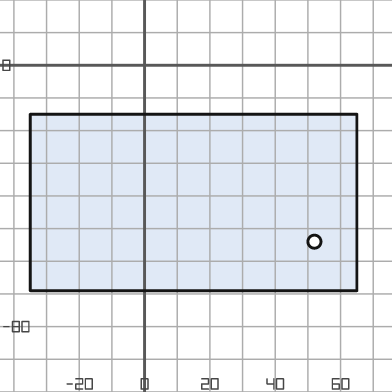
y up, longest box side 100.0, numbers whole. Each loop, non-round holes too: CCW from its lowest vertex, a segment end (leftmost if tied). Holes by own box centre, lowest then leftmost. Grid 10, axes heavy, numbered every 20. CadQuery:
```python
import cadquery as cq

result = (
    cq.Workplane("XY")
    .moveTo(-35.0, -69.0)
    .lineTo(65.0, -69.0)
    .lineTo(65.0, -15.0)
    .lineTo(-35.0, -15.0)
    .close()
    .moveTo(52.0, -54.0)
    .circle(2.0)
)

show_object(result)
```